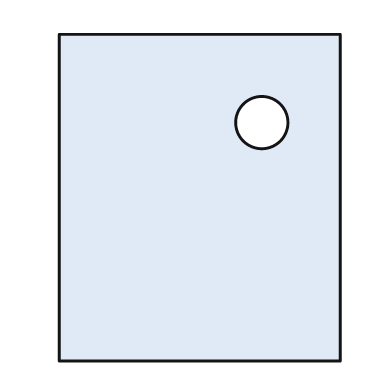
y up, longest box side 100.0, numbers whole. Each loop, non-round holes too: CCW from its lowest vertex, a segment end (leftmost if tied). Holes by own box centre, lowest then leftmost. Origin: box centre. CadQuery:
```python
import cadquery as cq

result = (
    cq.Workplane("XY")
    .moveTo(-43.0, -50.0)
    .lineTo(43.0, -50.0)
    .lineTo(43.0, 50.0)
    .lineTo(-43.0, 50.0)
    .close()
    .moveTo(19.0, 23.0)
    .circle(8.0)
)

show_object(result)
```